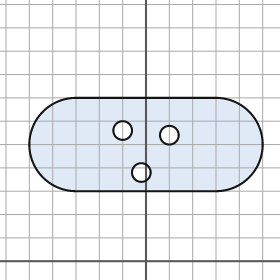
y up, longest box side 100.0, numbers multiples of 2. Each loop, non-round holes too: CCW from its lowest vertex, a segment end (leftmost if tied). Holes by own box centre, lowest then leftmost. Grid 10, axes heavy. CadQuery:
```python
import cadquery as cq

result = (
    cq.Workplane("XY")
    .moveTo(-30.0, 30.0)
    .lineTo(30.0, 30.0)
    .threePointArc((50.0, 50.0), (30.0, 70.0))
    .lineTo(-30.0, 70.0)
    .threePointArc((-50.0, 50.0), (-30.0, 30.0))
    .close()
    .moveTo(-2.0, 38.0)
    .circle(4.0)
    .moveTo(10.0, 54.0)
    .circle(4.0)
    .moveTo(-10.0, 56.0)
    .circle(4.0)
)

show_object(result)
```